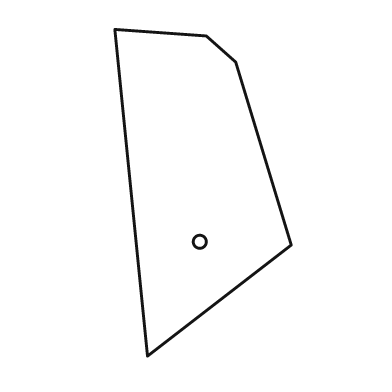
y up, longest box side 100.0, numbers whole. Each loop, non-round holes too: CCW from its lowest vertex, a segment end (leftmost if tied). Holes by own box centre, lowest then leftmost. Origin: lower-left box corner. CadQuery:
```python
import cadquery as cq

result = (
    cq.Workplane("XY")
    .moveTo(10.0, 0.0)
    .lineTo(54.0, 34.0)
    .lineTo(37.0, 90.0)
    .lineTo(28.0, 98.0)
    .lineTo(0.0, 100.0)
    .close()
    .moveTo(26.0, 35.0)
    .circle(2.0)
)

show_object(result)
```